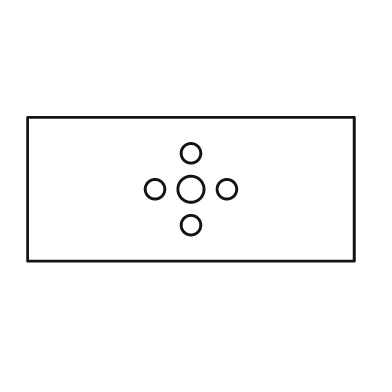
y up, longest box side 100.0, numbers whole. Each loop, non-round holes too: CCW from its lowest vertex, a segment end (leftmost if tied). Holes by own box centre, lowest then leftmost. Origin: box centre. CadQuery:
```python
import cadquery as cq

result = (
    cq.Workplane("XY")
    .moveTo(-50.0, -22.0)
    .lineTo(50.0, -22.0)
    .lineTo(50.0, 22.0)
    .lineTo(-50.0, 22.0)
    .close()
    .moveTo(0.0, -11.0)
    .circle(3.0)
    .moveTo(-11.0, 0.0)
    .circle(3.0)
    .moveTo(0.0, 0.0)
    .circle(4.0)
    .moveTo(11.0, 0.0)
    .circle(3.0)
    .moveTo(0.0, 11.0)
    .circle(3.0)
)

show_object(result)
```